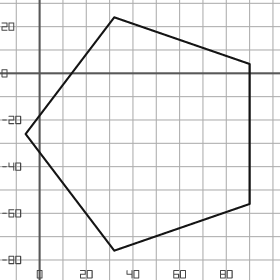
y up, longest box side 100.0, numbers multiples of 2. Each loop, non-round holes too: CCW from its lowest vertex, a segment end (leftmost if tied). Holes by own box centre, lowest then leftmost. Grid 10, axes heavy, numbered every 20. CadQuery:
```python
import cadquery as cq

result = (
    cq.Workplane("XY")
    .moveTo(32.0, -76.0)
    .lineTo(90.0, -56.0)
    .lineTo(90.0, 4.0)
    .lineTo(32.0, 24.0)
    .lineTo(-6.0, -26.0)
    .close()
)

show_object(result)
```